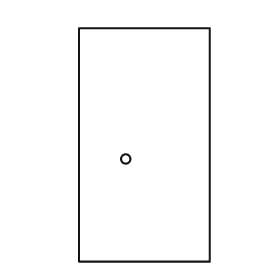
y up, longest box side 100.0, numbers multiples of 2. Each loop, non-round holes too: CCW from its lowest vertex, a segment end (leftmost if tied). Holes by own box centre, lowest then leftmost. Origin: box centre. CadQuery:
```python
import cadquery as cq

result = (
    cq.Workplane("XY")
    .moveTo(-28.0, -50.0)
    .lineTo(28.0, -50.0)
    .lineTo(28.0, 50.0)
    .lineTo(-28.0, 50.0)
    .close()
    .moveTo(-8.0, -6.0)
    .circle(2.0)
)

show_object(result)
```